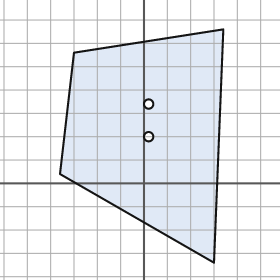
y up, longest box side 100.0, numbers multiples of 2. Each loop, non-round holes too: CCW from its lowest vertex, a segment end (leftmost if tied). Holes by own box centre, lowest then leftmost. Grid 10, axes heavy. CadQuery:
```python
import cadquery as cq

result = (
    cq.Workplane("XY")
    .moveTo(30.0, -34.0)
    .lineTo(34.0, 66.0)
    .lineTo(-30.0, 56.0)
    .lineTo(-36.0, 4.0)
    .close()
    .moveTo(2.0, 20.0)
    .circle(2.0)
    .moveTo(2.0, 34.0)
    .circle(2.0)
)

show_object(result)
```